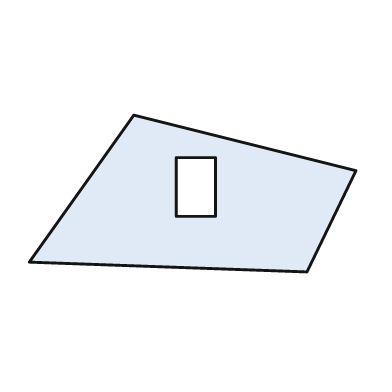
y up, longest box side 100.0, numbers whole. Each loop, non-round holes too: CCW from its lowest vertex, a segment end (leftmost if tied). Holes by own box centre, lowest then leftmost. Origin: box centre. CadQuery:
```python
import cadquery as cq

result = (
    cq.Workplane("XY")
    .moveTo(35.0, -24.0)
    .lineTo(50.0, 7.0)
    .lineTo(-18.0, 24.0)
    .lineTo(-50.0, -21.0)
    .close()
    .moveTo(-5.0, -7.0)
    .lineTo(7.0, -7.0)
    .lineTo(7.0, 11.0)
    .lineTo(-5.0, 11.0)
    .close()
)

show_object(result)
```